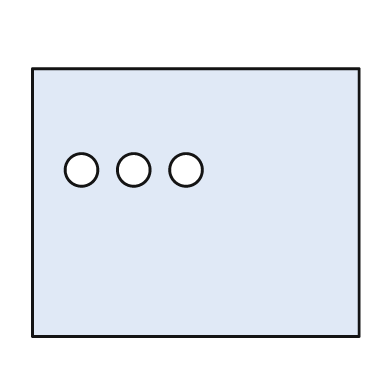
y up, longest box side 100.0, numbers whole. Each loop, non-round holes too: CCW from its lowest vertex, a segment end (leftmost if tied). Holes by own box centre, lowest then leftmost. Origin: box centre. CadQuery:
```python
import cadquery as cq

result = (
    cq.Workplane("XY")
    .moveTo(-50.0, -41.0)
    .lineTo(50.0, -41.0)
    .lineTo(50.0, 41.0)
    .lineTo(-50.0, 41.0)
    .close()
    .moveTo(-35.0, 10.0)
    .circle(5.0)
    .moveTo(-19.0, 10.0)
    .circle(5.0)
    .moveTo(-3.0, 10.0)
    .circle(5.0)
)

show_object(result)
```